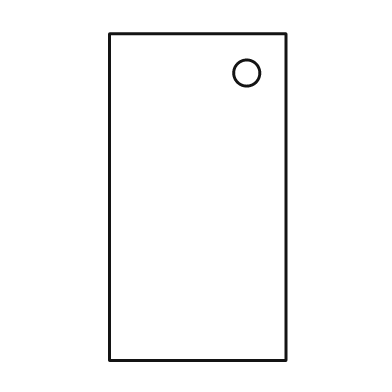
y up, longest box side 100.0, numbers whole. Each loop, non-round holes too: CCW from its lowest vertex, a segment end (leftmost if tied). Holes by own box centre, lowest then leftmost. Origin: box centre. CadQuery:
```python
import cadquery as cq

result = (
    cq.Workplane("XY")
    .moveTo(-27.0, -50.0)
    .lineTo(27.0, -50.0)
    .lineTo(27.0, 50.0)
    .lineTo(-27.0, 50.0)
    .close()
    .moveTo(15.0, 38.0)
    .circle(4.0)
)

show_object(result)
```